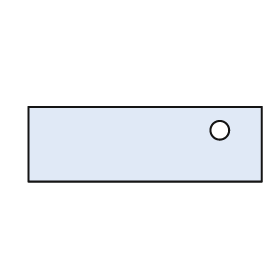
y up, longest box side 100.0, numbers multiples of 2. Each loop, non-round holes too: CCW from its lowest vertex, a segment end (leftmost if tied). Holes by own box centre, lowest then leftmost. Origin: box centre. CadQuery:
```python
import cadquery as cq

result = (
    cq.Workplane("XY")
    .moveTo(-50.0, -16.0)
    .lineTo(50.0, -16.0)
    .lineTo(50.0, 16.0)
    .lineTo(-50.0, 16.0)
    .close()
    .moveTo(32.0, 6.0)
    .circle(4.0)
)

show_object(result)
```